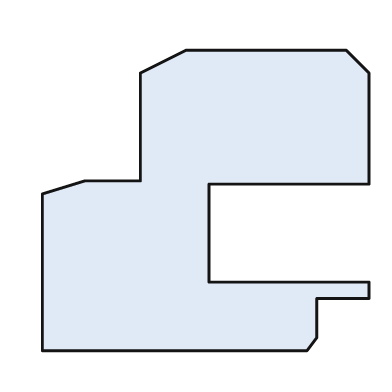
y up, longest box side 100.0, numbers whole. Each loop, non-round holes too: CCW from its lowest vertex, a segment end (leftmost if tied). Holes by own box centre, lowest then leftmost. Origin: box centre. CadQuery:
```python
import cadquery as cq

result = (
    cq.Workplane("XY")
    .moveTo(-50.0, -46.0)
    .lineTo(31.0, -46.0)
    .lineTo(34.0, -42.0)
    .lineTo(34.0, -30.0)
    .lineTo(50.0, -30.0)
    .lineTo(50.0, -25.0)
    .lineTo(1.0, -25.0)
    .lineTo(1.0, 5.0)
    .lineTo(50.0, 5.0)
    .lineTo(50.0, 39.0)
    .lineTo(43.0, 46.0)
    .lineTo(-6.0, 46.0)
    .lineTo(-20.0, 39.0)
    .lineTo(-20.0, 6.0)
    .lineTo(-37.0, 6.0)
    .lineTo(-50.0, 2.0)
    .close()
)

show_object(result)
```